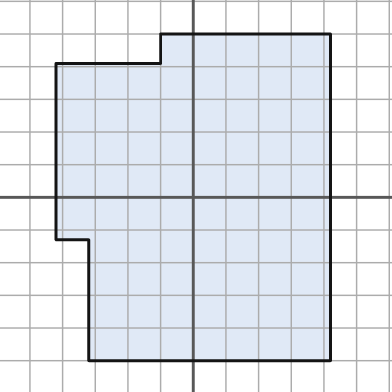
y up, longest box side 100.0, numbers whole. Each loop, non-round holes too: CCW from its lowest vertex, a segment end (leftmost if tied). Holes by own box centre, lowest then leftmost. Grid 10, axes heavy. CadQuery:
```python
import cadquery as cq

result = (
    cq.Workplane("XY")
    .moveTo(-32.0, -50.0)
    .lineTo(42.0, -50.0)
    .lineTo(42.0, 50.0)
    .lineTo(-10.0, 50.0)
    .lineTo(-10.0, 41.0)
    .lineTo(-42.0, 41.0)
    .lineTo(-42.0, -13.0)
    .lineTo(-32.0, -13.0)
    .close()
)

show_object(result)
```